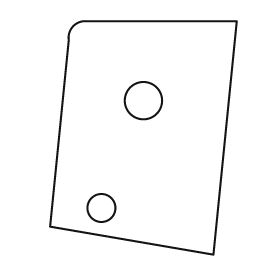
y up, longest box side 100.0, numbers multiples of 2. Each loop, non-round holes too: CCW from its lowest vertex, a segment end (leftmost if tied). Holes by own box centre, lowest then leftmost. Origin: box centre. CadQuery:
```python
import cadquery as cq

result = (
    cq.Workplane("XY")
    .moveTo(30.0, -50.0)
    .lineTo(40.0, 50.0)
    .lineTo(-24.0, 50.0)
    .threePointArc((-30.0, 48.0), (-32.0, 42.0))
    .lineTo(-40.0, -38.0)
    .close()
    .moveTo(-18.0, -30.0)
    .circle(6.0)
    .moveTo(0.0, 16.0)
    .circle(8.0)
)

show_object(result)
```